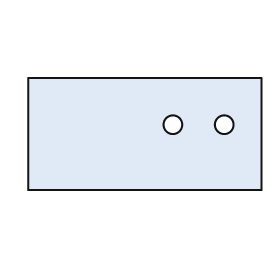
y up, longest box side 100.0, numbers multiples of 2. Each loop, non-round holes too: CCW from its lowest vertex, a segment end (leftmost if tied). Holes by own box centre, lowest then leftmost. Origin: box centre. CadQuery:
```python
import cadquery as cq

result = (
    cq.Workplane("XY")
    .moveTo(-50.0, -24.0)
    .lineTo(50.0, -24.0)
    .lineTo(50.0, 24.0)
    .lineTo(-50.0, 24.0)
    .close()
    .moveTo(12.0, 4.0)
    .circle(4.0)
    .moveTo(34.0, 4.0)
    .circle(4.0)
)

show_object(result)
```